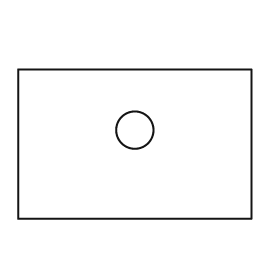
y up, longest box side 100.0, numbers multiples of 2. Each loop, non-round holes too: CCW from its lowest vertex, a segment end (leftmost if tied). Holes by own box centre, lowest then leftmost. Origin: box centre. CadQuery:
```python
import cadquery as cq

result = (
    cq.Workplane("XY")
    .moveTo(-50.0, -32.0)
    .lineTo(50.0, -32.0)
    .lineTo(50.0, 32.0)
    .lineTo(-50.0, 32.0)
    .close()
    .moveTo(0.0, 6.0)
    .circle(8.0)
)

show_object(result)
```